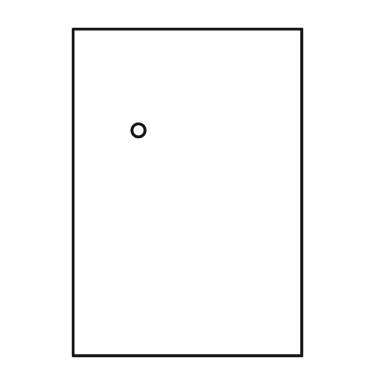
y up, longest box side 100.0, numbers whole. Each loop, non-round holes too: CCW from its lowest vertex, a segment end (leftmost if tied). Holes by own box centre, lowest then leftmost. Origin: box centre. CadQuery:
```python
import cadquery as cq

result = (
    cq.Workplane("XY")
    .moveTo(-35.0, -50.0)
    .lineTo(35.0, -50.0)
    .lineTo(35.0, 50.0)
    .lineTo(-35.0, 50.0)
    .close()
    .moveTo(-15.0, 19.0)
    .circle(2.0)
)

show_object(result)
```